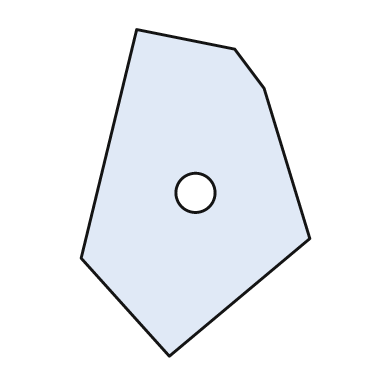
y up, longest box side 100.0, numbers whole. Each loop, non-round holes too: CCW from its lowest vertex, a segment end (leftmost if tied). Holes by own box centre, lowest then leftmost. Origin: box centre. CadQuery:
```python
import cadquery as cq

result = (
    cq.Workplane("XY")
    .moveTo(-8.0, -50.0)
    .lineTo(35.0, -14.0)
    .lineTo(21.0, 32.0)
    .lineTo(12.0, 44.0)
    .lineTo(-18.0, 50.0)
    .lineTo(-35.0, -20.0)
    .close()
    .moveTo(0.0, 0.0)
    .circle(6.0)
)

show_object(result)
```